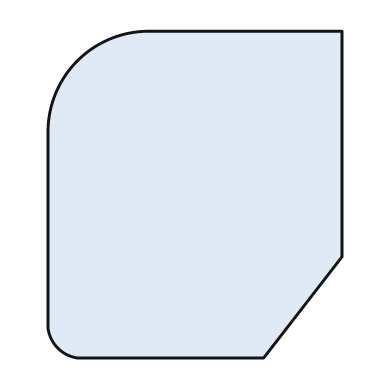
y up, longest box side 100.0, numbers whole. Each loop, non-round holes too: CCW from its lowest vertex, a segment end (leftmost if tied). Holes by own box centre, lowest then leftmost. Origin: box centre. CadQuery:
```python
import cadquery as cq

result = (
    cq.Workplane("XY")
    .moveTo(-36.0, -50.0)
    .lineTo(21.0, -50.0)
    .lineTo(45.0, -19.0)
    .lineTo(45.0, 50.0)
    .lineTo(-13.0, 50.0)
    .threePointArc((-36.0, 41.0), (-45.0, 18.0))
    .lineTo(-45.0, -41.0)
    .threePointArc((-42.0, -47.0), (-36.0, -50.0))
    .close()
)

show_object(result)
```